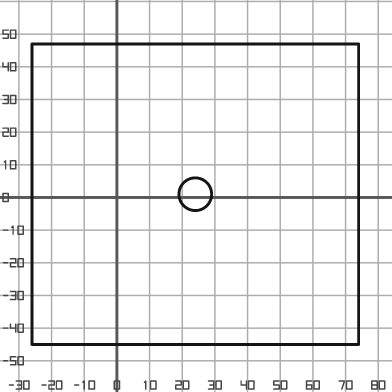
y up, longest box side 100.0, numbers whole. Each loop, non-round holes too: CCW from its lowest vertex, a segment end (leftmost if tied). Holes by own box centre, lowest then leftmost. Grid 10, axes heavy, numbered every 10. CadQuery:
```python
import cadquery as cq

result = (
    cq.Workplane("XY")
    .moveTo(-26.0, -45.0)
    .lineTo(74.0, -45.0)
    .lineTo(74.0, 47.0)
    .lineTo(-26.0, 47.0)
    .close()
    .moveTo(24.0, 1.0)
    .circle(5.0)
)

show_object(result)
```